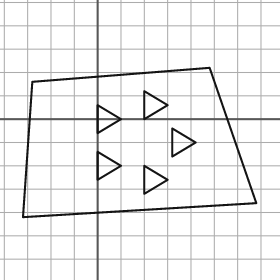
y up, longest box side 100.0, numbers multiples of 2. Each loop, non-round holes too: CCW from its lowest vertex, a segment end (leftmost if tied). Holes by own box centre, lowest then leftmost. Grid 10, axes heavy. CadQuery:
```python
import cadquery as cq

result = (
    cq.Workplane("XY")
    .moveTo(-32.0, -42.0)
    .lineTo(68.0, -36.0)
    .lineTo(48.0, 22.0)
    .lineTo(-28.0, 16.0)
    .close()
    .moveTo(20.0, -32.0)
    .lineTo(30.0, -26.0)
    .lineTo(20.0, -20.0)
    .close()
    .moveTo(0.0, -26.0)
    .lineTo(10.0, -20.0)
    .lineTo(0.0, -14.0)
    .close()
    .moveTo(32.0, -16.0)
    .lineTo(42.0, -10.0)
    .lineTo(32.0, -4.0)
    .close()
    .moveTo(0.0, -6.0)
    .lineTo(10.0, 0.0)
    .lineTo(0.0, 6.0)
    .close()
    .moveTo(20.0, 0.0)
    .lineTo(30.0, 6.0)
    .lineTo(20.0, 12.0)
    .close()
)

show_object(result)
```